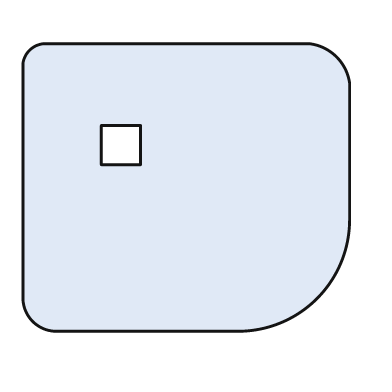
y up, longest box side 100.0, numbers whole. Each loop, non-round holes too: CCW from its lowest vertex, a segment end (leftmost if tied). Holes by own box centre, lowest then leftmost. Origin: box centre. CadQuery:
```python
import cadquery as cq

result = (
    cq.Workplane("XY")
    .moveTo(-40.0, -44.0)
    .lineTo(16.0, -44.0)
    .threePointArc((40.0, -34.0), (50.0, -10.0))
    .lineTo(50.0, 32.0)
    .threePointArc((46.0, 40.0), (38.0, 44.0))
    .lineTo(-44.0, 44.0)
    .threePointArc((-48.0, 42.0), (-50.0, 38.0))
    .lineTo(-50.0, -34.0)
    .threePointArc((-47.0, -41.0), (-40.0, -44.0))
    .close()
    .moveTo(-26.0, 7.0)
    .lineTo(-14.0, 7.0)
    .lineTo(-14.0, 19.0)
    .lineTo(-26.0, 19.0)
    .close()
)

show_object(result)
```